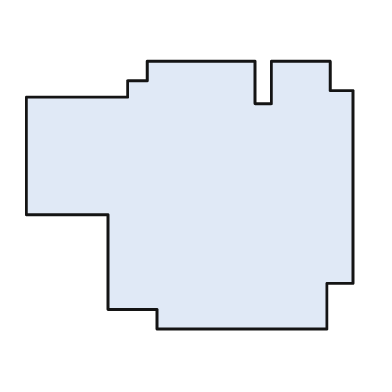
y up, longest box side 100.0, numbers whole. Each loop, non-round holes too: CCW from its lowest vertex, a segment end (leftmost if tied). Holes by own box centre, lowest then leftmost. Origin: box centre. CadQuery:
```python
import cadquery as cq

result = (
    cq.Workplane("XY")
    .moveTo(-10.0, -41.0)
    .lineTo(42.0, -41.0)
    .lineTo(42.0, -27.0)
    .lineTo(50.0, -27.0)
    .lineTo(50.0, 32.0)
    .lineTo(43.0, 32.0)
    .lineTo(43.0, 41.0)
    .lineTo(25.0, 41.0)
    .lineTo(25.0, 28.0)
    .lineTo(20.0, 28.0)
    .lineTo(20.0, 41.0)
    .lineTo(-13.0, 41.0)
    .lineTo(-13.0, 35.0)
    .lineTo(-19.0, 35.0)
    .lineTo(-19.0, 30.0)
    .lineTo(-50.0, 30.0)
    .lineTo(-50.0, -6.0)
    .lineTo(-25.0, -6.0)
    .lineTo(-25.0, -35.0)
    .lineTo(-10.0, -35.0)
    .close()
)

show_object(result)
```